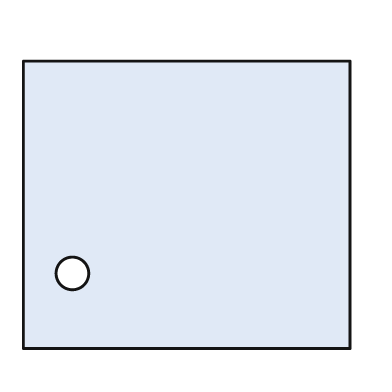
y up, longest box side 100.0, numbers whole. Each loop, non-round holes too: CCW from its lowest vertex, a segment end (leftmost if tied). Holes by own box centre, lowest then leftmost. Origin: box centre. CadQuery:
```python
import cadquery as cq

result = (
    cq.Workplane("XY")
    .moveTo(-50.0, -44.0)
    .lineTo(50.0, -44.0)
    .lineTo(50.0, 44.0)
    .lineTo(-50.0, 44.0)
    .close()
    .moveTo(-35.0, -21.0)
    .circle(5.0)
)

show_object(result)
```